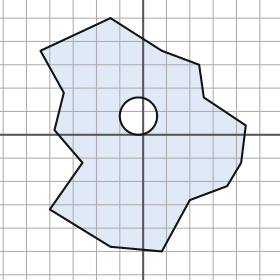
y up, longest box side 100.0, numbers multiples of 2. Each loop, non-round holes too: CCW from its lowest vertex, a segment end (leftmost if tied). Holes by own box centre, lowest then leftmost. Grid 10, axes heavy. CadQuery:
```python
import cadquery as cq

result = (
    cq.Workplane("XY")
    .moveTo(8.0, -50.0)
    .lineTo(20.0, -28.0)
    .lineTo(36.0, -22.0)
    .lineTo(42.0, -12.0)
    .lineTo(44.0, 4.0)
    .lineTo(26.0, 16.0)
    .lineTo(24.0, 30.0)
    .lineTo(8.0, 36.0)
    .lineTo(-14.0, 50.0)
    .lineTo(-44.0, 36.0)
    .lineTo(-34.0, 18.0)
    .lineTo(-38.0, 2.0)
    .lineTo(-26.0, -12.0)
    .lineTo(-40.0, -32.0)
    .lineTo(-14.0, -48.0)
    .close()
    .moveTo(-2.0, 8.0)
    .circle(8.0)
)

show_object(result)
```